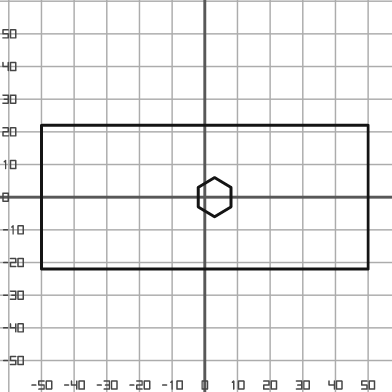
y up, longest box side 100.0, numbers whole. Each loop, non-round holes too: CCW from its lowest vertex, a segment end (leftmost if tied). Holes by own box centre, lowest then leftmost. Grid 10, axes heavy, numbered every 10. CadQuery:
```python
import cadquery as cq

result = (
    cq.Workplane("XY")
    .moveTo(-50.0, -22.0)
    .lineTo(50.0, -22.0)
    .lineTo(50.0, 22.0)
    .lineTo(-50.0, 22.0)
    .close()
    .moveTo(3.0, -6.0)
    .lineTo(8.0, -3.0)
    .lineTo(8.0, 3.0)
    .lineTo(3.0, 6.0)
    .lineTo(-2.0, 3.0)
    .lineTo(-2.0, -3.0)
    .close()
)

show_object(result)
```